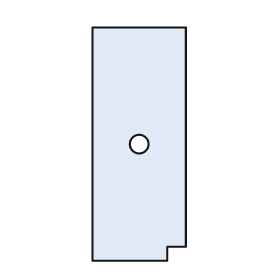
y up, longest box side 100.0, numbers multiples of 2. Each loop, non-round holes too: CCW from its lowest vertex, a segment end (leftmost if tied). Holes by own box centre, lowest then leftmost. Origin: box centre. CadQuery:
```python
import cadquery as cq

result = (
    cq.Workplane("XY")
    .moveTo(-20.0, -50.0)
    .lineTo(12.0, -50.0)
    .lineTo(12.0, -44.0)
    .lineTo(20.0, -44.0)
    .lineTo(20.0, 50.0)
    .lineTo(-20.0, 50.0)
    .close()
    .moveTo(0.0, 0.0)
    .circle(4.0)
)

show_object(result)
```